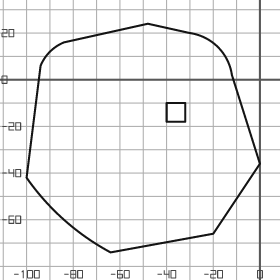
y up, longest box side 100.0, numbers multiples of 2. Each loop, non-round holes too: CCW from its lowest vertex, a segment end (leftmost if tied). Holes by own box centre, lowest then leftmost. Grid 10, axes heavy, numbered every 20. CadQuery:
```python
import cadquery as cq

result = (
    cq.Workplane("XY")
    .moveTo(-64.0, -74.0)
    .lineTo(-20.0, -66.0)
    .lineTo(0.0, -36.0)
    .lineTo(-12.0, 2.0)
    .threePointArc((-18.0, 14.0), (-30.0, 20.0))
    .lineTo(-48.0, 24.0)
    .lineTo(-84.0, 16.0)
    .threePointArc((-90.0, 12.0), (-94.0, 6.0))
    .lineTo(-100.0, -42.0)
    .threePointArc((-84.0, -60.0), (-64.0, -74.0))
    .close()
    .moveTo(-40.0, -18.0)
    .lineTo(-32.0, -18.0)
    .lineTo(-32.0, -10.0)
    .lineTo(-40.0, -10.0)
    .close()
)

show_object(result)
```